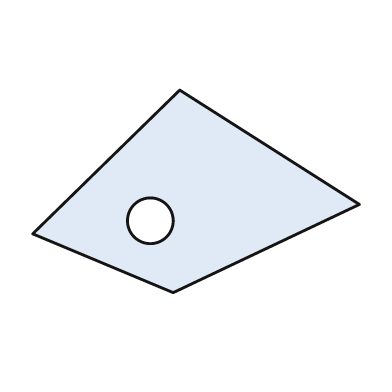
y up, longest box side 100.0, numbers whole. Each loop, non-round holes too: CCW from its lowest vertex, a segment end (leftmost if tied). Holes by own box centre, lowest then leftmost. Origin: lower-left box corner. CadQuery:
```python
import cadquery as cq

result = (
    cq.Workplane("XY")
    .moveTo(43.0, 0.0)
    .lineTo(100.0, 27.0)
    .lineTo(45.0, 62.0)
    .lineTo(0.0, 18.0)
    .close()
    .moveTo(36.0, 22.0)
    .circle(7.0)
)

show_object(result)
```